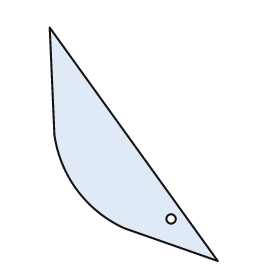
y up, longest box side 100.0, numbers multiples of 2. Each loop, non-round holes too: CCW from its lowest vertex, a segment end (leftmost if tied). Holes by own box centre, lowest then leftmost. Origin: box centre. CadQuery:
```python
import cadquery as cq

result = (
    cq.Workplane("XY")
    .moveTo(36.0, -50.0)
    .lineTo(-36.0, 50.0)
    .lineTo(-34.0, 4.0)
    .threePointArc((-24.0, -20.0), (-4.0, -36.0))
    .close()
    .moveTo(16.0, -32.0)
    .circle(2.0)
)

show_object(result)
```